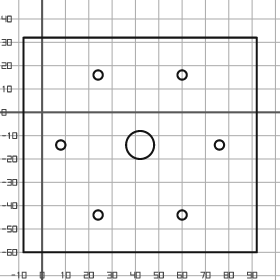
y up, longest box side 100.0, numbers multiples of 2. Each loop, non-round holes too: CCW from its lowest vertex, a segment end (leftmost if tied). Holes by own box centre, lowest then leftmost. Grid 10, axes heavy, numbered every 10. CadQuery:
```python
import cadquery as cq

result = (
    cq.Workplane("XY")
    .moveTo(-8.0, -60.0)
    .lineTo(92.0, -60.0)
    .lineTo(92.0, 32.0)
    .lineTo(-8.0, 32.0)
    .close()
    .moveTo(24.0, -44.0)
    .circle(2.0)
    .moveTo(60.0, -44.0)
    .circle(2.0)
    .moveTo(8.0, -14.0)
    .circle(2.0)
    .moveTo(42.0, -14.0)
    .circle(6.0)
    .moveTo(76.0, -14.0)
    .circle(2.0)
    .moveTo(24.0, 16.0)
    .circle(2.0)
    .moveTo(60.0, 16.0)
    .circle(2.0)
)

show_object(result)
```